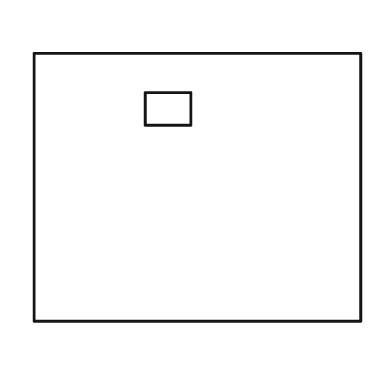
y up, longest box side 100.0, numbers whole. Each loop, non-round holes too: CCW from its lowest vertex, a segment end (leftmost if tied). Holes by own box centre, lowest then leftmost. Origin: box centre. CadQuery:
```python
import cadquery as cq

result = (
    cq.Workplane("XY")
    .moveTo(-50.0, -41.0)
    .lineTo(50.0, -41.0)
    .lineTo(50.0, 41.0)
    .lineTo(-50.0, 41.0)
    .close()
    .moveTo(-16.0, 19.0)
    .lineTo(-2.0, 19.0)
    .lineTo(-2.0, 29.0)
    .lineTo(-16.0, 29.0)
    .close()
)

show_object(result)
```